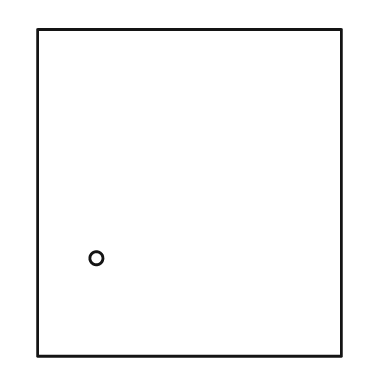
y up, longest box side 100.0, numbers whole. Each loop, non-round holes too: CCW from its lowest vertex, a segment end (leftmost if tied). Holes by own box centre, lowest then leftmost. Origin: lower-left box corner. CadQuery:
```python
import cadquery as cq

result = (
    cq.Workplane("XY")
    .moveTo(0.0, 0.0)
    .lineTo(93.0, 0.0)
    .lineTo(93.0, 100.0)
    .lineTo(0.0, 100.0)
    .close()
    .moveTo(18.0, 30.0)
    .circle(2.0)
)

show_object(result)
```